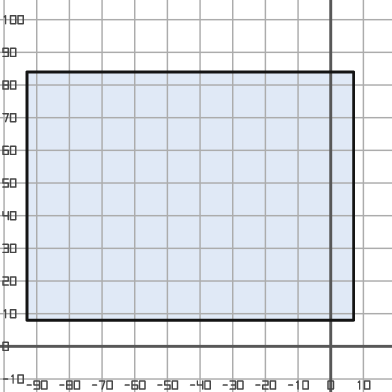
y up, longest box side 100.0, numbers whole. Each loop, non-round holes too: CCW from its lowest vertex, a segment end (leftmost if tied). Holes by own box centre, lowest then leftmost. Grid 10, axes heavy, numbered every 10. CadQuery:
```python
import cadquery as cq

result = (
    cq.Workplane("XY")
    .moveTo(-93.0, 8.0)
    .lineTo(7.0, 8.0)
    .lineTo(7.0, 84.0)
    .lineTo(-93.0, 84.0)
    .close()
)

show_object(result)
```